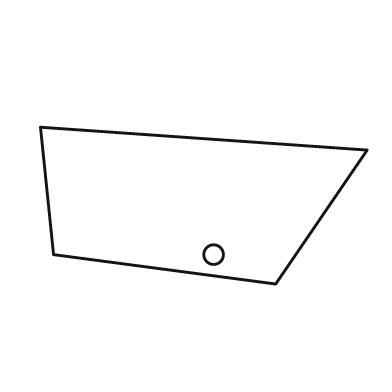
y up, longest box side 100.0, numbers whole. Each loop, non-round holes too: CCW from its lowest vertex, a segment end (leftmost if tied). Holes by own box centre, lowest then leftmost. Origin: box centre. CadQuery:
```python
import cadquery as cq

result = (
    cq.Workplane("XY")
    .moveTo(22.0, -24.0)
    .lineTo(50.0, 17.0)
    .lineTo(-50.0, 24.0)
    .lineTo(-46.0, -15.0)
    .close()
    .moveTo(3.0, -15.0)
    .circle(3.0)
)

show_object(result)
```